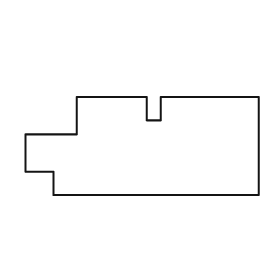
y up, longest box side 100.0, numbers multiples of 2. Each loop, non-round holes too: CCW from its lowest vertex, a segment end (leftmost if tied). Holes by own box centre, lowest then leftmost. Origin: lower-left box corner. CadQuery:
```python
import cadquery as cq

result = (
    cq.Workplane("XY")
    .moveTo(12.0, 0.0)
    .lineTo(100.0, 0.0)
    .lineTo(100.0, 42.0)
    .lineTo(58.0, 42.0)
    .lineTo(58.0, 32.0)
    .lineTo(52.0, 32.0)
    .lineTo(52.0, 42.0)
    .lineTo(22.0, 42.0)
    .lineTo(22.0, 26.0)
    .lineTo(0.0, 26.0)
    .lineTo(0.0, 10.0)
    .lineTo(12.0, 10.0)
    .close()
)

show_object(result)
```